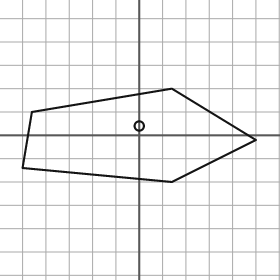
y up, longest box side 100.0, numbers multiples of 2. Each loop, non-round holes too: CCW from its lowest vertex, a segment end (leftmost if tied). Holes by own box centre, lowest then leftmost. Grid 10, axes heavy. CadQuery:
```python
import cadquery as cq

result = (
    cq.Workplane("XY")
    .moveTo(14.0, -20.0)
    .lineTo(50.0, -2.0)
    .lineTo(14.0, 20.0)
    .lineTo(-46.0, 10.0)
    .lineTo(-50.0, -14.0)
    .close()
    .moveTo(0.0, 4.0)
    .circle(2.0)
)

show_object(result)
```